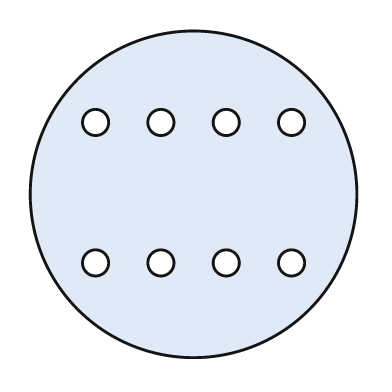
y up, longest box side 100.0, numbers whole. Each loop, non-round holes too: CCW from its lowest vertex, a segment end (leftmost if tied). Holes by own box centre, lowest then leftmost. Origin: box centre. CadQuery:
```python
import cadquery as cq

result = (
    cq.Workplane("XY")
    .moveTo(0.0, 0.0)
    .circle(50.0)
    .moveTo(-30.0, -21.0)
    .circle(4.0)
    .moveTo(-10.0, -21.0)
    .circle(4.0)
    .moveTo(10.0, -21.0)
    .circle(4.0)
    .moveTo(30.0, -21.0)
    .circle(4.0)
    .moveTo(-30.0, 22.0)
    .circle(4.0)
    .moveTo(-10.0, 22.0)
    .circle(4.0)
    .moveTo(10.0, 22.0)
    .circle(4.0)
    .moveTo(30.0, 22.0)
    .circle(4.0)
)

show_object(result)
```